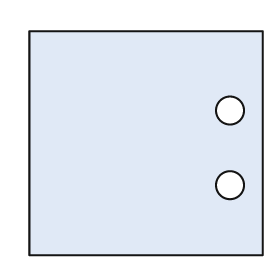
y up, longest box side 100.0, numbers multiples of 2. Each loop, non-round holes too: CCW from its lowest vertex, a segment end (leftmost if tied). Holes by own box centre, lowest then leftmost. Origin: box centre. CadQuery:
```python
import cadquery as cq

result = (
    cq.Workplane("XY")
    .moveTo(-50.0, -48.0)
    .lineTo(50.0, -48.0)
    .lineTo(50.0, 48.0)
    .lineTo(-50.0, 48.0)
    .close()
    .moveTo(36.0, -18.0)
    .circle(6.0)
    .moveTo(36.0, 14.0)
    .circle(6.0)
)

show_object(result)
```